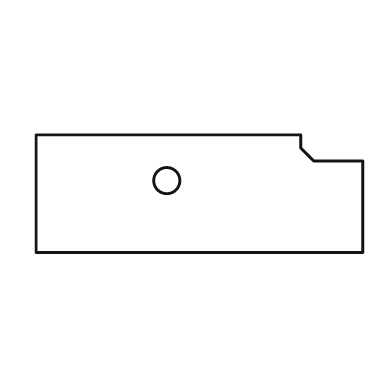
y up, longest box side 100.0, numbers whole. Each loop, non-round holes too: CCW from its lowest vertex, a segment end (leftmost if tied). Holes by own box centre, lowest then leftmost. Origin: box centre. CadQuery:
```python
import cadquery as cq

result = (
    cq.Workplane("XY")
    .moveTo(-50.0, -18.0)
    .lineTo(50.0, -18.0)
    .lineTo(50.0, 10.0)
    .lineTo(35.0, 10.0)
    .lineTo(31.0, 14.0)
    .lineTo(31.0, 18.0)
    .lineTo(-50.0, 18.0)
    .close()
    .moveTo(-10.0, 4.0)
    .circle(4.0)
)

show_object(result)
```